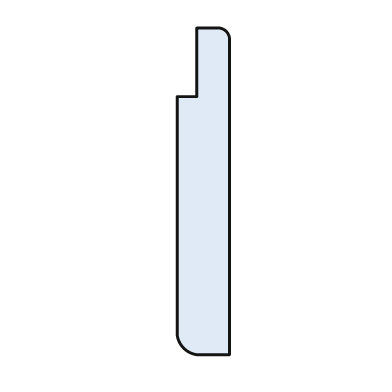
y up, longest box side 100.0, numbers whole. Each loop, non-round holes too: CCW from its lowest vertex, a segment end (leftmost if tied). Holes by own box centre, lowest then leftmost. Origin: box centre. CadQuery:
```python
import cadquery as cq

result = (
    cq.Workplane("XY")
    .moveTo(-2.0, -50.0)
    .lineTo(8.0, -50.0)
    .lineTo(8.0, 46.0)
    .threePointArc((7.0, 49.0), (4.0, 50.0))
    .lineTo(-2.0, 50.0)
    .lineTo(-2.0, 29.0)
    .lineTo(-8.0, 29.0)
    .lineTo(-8.0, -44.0)
    .threePointArc((-6.0, -48.0), (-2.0, -50.0))
    .close()
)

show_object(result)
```